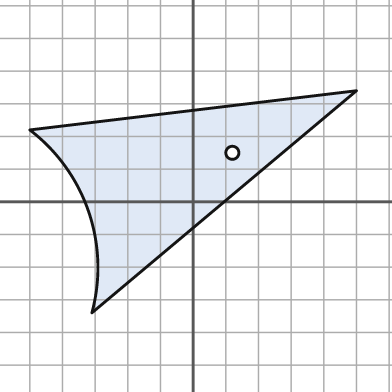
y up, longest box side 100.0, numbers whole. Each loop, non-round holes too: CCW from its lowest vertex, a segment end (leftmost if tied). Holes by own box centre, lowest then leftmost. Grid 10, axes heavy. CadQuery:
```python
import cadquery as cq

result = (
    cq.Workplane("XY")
    .moveTo(-31.0, -34.0)
    .lineTo(50.0, 34.0)
    .lineTo(-50.0, 22.0)
    .threePointArc((-32.0, -3.0), (-31.0, -34.0))
    .close()
    .moveTo(12.0, 15.0)
    .circle(2.0)
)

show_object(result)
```